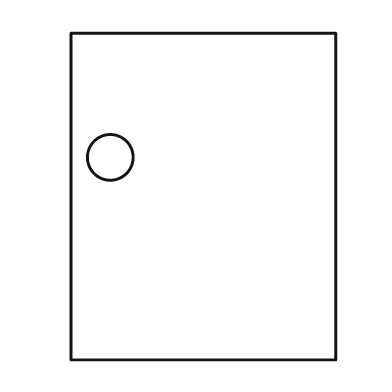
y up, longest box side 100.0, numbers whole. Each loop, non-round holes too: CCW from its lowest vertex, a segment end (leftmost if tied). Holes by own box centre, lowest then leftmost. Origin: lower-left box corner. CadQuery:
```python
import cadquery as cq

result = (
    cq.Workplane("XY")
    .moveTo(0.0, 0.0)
    .lineTo(81.0, 0.0)
    .lineTo(81.0, 100.0)
    .lineTo(0.0, 100.0)
    .close()
    .moveTo(12.0, 62.0)
    .circle(7.0)
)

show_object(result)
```